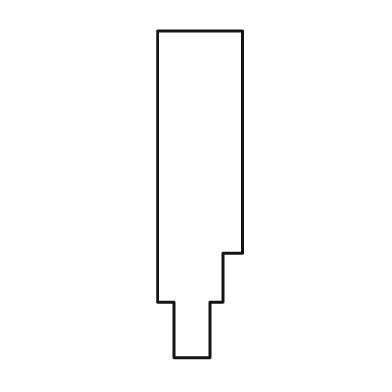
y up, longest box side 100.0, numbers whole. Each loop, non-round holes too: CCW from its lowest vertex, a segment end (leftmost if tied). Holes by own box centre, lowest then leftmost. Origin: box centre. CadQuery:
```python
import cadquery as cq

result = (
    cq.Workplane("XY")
    .moveTo(-8.0, -50.0)
    .lineTo(3.0, -50.0)
    .lineTo(3.0, -33.0)
    .lineTo(7.0, -33.0)
    .lineTo(7.0, -18.0)
    .lineTo(13.0, -18.0)
    .lineTo(13.0, 50.0)
    .lineTo(-13.0, 50.0)
    .lineTo(-13.0, -33.0)
    .lineTo(-8.0, -33.0)
    .close()
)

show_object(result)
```